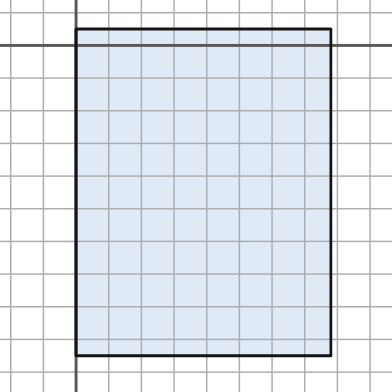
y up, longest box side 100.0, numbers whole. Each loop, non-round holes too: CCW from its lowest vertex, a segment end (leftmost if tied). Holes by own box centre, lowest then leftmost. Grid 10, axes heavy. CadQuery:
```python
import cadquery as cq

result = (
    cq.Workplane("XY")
    .moveTo(0.0, -95.0)
    .lineTo(78.0, -95.0)
    .lineTo(78.0, 5.0)
    .lineTo(0.0, 5.0)
    .close()
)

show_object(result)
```